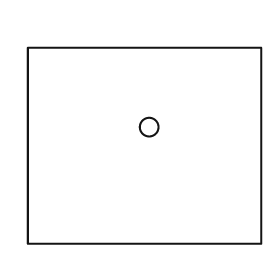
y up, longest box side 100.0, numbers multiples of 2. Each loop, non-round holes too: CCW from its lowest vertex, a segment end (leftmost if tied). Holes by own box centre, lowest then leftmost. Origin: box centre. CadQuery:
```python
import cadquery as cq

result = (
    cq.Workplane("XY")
    .moveTo(-50.0, -42.0)
    .lineTo(50.0, -42.0)
    .lineTo(50.0, 42.0)
    .lineTo(-50.0, 42.0)
    .close()
    .moveTo(2.0, 8.0)
    .circle(4.0)
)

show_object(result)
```